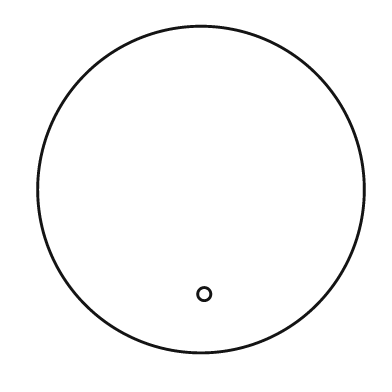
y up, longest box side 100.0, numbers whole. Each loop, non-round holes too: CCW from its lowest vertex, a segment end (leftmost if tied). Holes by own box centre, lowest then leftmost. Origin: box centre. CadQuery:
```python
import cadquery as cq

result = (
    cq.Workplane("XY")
    .moveTo(0.0, 0.0)
    .circle(50.0)
    .moveTo(1.0, -32.0)
    .circle(2.0)
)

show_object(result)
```